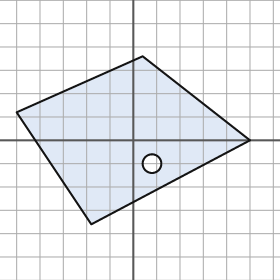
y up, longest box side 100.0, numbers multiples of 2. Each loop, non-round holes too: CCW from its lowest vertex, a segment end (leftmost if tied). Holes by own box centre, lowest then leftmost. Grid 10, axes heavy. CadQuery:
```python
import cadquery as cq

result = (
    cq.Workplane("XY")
    .moveTo(-18.0, -36.0)
    .lineTo(50.0, 0.0)
    .lineTo(4.0, 36.0)
    .lineTo(-50.0, 12.0)
    .close()
    .moveTo(8.0, -10.0)
    .circle(4.0)
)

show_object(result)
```